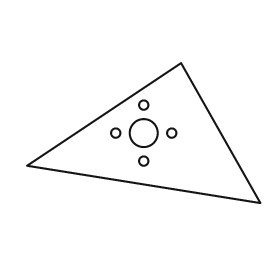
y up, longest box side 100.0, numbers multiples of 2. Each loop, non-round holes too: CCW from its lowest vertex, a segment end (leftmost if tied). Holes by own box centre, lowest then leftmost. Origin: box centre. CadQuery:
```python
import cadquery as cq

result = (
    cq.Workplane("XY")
    .moveTo(50.0, -30.0)
    .lineTo(16.0, 30.0)
    .lineTo(-50.0, -14.0)
    .close()
    .moveTo(0.0, -12.0)
    .circle(2.0)
    .moveTo(-12.0, 0.0)
    .circle(2.0)
    .moveTo(0.0, 0.0)
    .circle(6.0)
    .moveTo(12.0, 0.0)
    .circle(2.0)
    .moveTo(0.0, 12.0)
    .circle(2.0)
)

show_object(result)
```